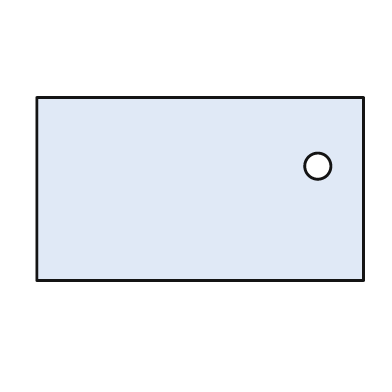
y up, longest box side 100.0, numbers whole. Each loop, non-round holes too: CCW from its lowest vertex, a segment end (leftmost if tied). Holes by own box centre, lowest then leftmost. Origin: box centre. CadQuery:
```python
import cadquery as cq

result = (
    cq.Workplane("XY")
    .moveTo(-50.0, -28.0)
    .lineTo(50.0, -28.0)
    .lineTo(50.0, 28.0)
    .lineTo(-50.0, 28.0)
    .close()
    .moveTo(36.0, 7.0)
    .circle(4.0)
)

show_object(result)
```